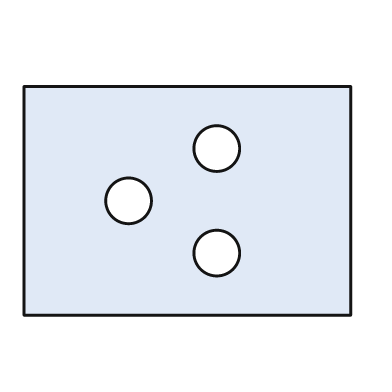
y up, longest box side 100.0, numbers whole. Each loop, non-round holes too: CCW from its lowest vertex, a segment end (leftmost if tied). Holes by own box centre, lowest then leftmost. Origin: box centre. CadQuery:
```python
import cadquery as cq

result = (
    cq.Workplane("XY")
    .moveTo(-50.0, -35.0)
    .lineTo(50.0, -35.0)
    .lineTo(50.0, 35.0)
    .lineTo(-50.0, 35.0)
    .close()
    .moveTo(9.0, -16.0)
    .circle(7.0)
    .moveTo(-18.0, 0.0)
    .circle(7.0)
    .moveTo(9.0, 16.0)
    .circle(7.0)
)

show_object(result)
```